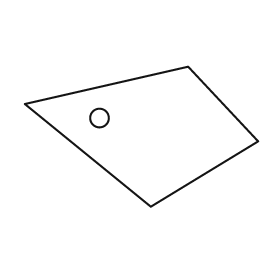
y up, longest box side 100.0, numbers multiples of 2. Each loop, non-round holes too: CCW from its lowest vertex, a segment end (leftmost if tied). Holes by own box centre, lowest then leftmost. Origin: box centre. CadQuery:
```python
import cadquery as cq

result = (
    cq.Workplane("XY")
    .moveTo(4.0, -30.0)
    .lineTo(50.0, -2.0)
    .lineTo(20.0, 30.0)
    .lineTo(-50.0, 14.0)
    .close()
    .moveTo(-18.0, 8.0)
    .circle(4.0)
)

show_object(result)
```